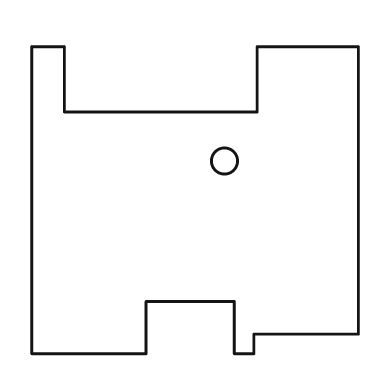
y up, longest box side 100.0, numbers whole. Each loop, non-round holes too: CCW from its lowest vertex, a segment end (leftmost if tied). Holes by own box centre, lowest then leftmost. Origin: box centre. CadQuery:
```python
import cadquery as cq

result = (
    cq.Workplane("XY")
    .moveTo(-50.0, -47.0)
    .lineTo(-15.0, -47.0)
    .lineTo(-15.0, -31.0)
    .lineTo(12.0, -31.0)
    .lineTo(12.0, -47.0)
    .lineTo(18.0, -47.0)
    .lineTo(18.0, -41.0)
    .lineTo(50.0, -41.0)
    .lineTo(50.0, 47.0)
    .lineTo(19.0, 47.0)
    .lineTo(19.0, 27.0)
    .lineTo(-40.0, 27.0)
    .lineTo(-40.0, 47.0)
    .lineTo(-50.0, 47.0)
    .close()
    .moveTo(9.0, 12.0)
    .circle(4.0)
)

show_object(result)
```